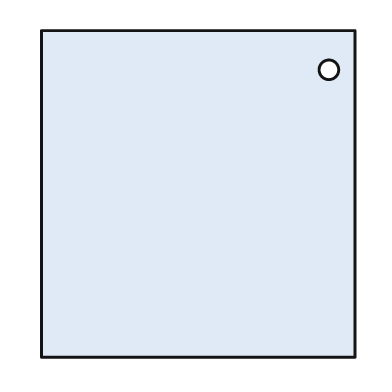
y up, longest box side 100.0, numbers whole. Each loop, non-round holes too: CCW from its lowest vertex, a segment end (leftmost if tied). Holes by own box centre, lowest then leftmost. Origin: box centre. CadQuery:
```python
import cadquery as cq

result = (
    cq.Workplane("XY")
    .moveTo(-48.0, -50.0)
    .lineTo(48.0, -50.0)
    .lineTo(48.0, 50.0)
    .lineTo(-48.0, 50.0)
    .close()
    .moveTo(40.0, 38.0)
    .circle(3.0)
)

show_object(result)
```